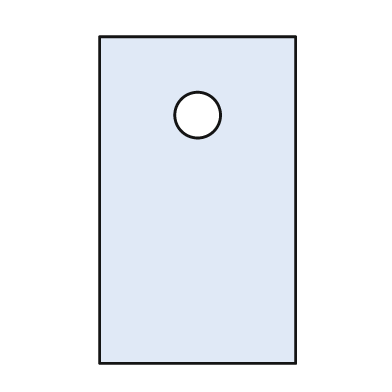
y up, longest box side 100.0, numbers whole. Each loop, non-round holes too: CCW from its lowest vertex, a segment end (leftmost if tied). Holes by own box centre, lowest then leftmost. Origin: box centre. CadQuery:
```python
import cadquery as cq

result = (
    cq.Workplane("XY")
    .moveTo(-30.0, -50.0)
    .lineTo(30.0, -50.0)
    .lineTo(30.0, 50.0)
    .lineTo(-30.0, 50.0)
    .close()
    .moveTo(0.0, 26.0)
    .circle(7.0)
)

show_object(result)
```